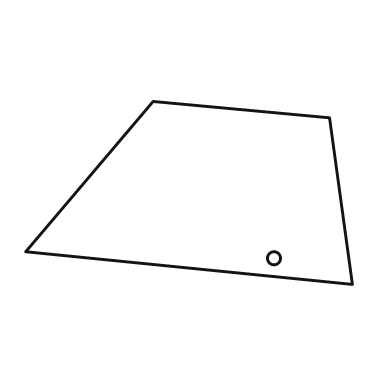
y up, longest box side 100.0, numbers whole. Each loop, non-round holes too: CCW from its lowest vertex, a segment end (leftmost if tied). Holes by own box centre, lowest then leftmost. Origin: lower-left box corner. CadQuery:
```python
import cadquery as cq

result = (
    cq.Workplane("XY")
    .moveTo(100.0, 0.0)
    .lineTo(93.0, 51.0)
    .lineTo(39.0, 56.0)
    .lineTo(0.0, 10.0)
    .close()
    .moveTo(76.0, 8.0)
    .circle(2.0)
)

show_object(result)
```